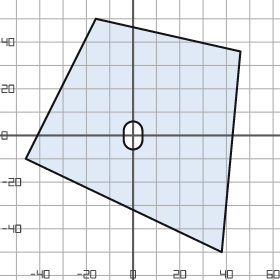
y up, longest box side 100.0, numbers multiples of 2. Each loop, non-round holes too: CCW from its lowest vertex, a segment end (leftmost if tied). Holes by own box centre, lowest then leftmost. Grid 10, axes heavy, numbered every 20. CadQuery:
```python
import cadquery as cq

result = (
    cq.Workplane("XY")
    .moveTo(38.0, -50.0)
    .lineTo(46.0, 36.0)
    .lineTo(-16.0, 50.0)
    .lineTo(-46.0, -10.0)
    .close()
    .moveTo(-4.0, -2.0)
    .threePointArc((0.0, -6.0), (4.0, -2.0))
    .lineTo(4.0, 2.0)
    .threePointArc((0.0, 6.0), (-4.0, 2.0))
    .close()
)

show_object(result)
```